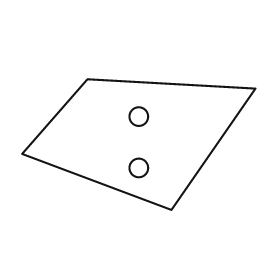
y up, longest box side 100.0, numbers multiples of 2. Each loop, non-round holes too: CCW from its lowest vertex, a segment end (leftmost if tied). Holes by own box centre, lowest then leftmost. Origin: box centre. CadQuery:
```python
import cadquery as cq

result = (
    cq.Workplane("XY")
    .moveTo(14.0, -28.0)
    .lineTo(50.0, 24.0)
    .lineTo(-22.0, 28.0)
    .lineTo(-50.0, -4.0)
    .close()
    .moveTo(0.0, -10.0)
    .circle(4.0)
    .moveTo(0.0, 12.0)
    .circle(4.0)
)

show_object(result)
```